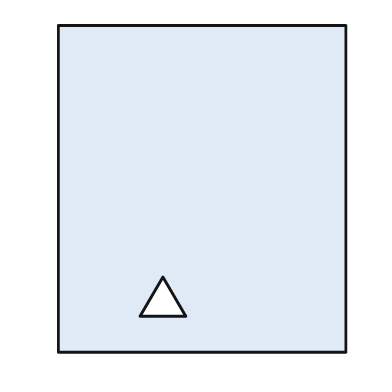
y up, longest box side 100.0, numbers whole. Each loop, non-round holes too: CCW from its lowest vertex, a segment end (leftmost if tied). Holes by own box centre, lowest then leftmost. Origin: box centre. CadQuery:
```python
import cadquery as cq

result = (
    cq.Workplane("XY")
    .moveTo(-44.0, -50.0)
    .lineTo(44.0, -50.0)
    .lineTo(44.0, 50.0)
    .lineTo(-44.0, 50.0)
    .close()
    .moveTo(-19.0, -39.0)
    .lineTo(-5.0, -39.0)
    .lineTo(-12.0, -27.0)
    .close()
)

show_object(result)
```